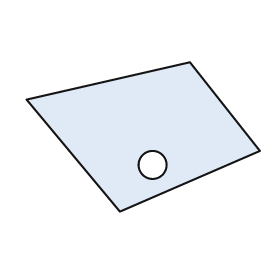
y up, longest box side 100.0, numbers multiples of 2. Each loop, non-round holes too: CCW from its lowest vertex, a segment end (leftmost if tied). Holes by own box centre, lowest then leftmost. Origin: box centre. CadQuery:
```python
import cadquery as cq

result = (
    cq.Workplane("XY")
    .moveTo(-10.0, -32.0)
    .lineTo(50.0, -6.0)
    .lineTo(20.0, 32.0)
    .lineTo(-50.0, 16.0)
    .close()
    .moveTo(4.0, -12.0)
    .circle(6.0)
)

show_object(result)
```